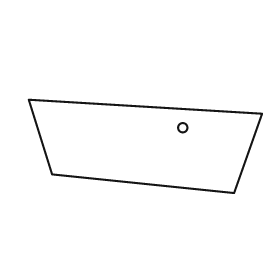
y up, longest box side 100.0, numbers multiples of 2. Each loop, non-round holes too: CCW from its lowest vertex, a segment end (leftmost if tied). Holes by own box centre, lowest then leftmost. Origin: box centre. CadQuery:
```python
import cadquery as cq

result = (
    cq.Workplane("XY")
    .moveTo(38.0, -20.0)
    .lineTo(50.0, 14.0)
    .lineTo(-50.0, 20.0)
    .lineTo(-40.0, -12.0)
    .close()
    .moveTo(16.0, 8.0)
    .circle(2.0)
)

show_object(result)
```